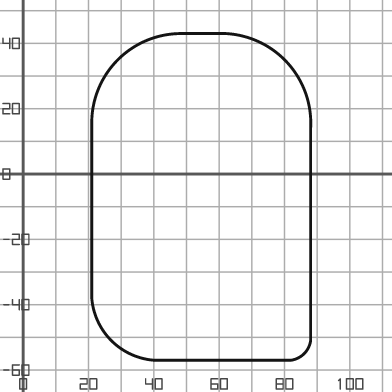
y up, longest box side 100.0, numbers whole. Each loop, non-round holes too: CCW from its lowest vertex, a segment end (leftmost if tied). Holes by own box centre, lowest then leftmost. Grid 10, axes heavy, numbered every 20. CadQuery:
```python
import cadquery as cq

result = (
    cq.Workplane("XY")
    .moveTo(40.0, -57.0)
    .lineTo(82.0, -57.0)
    .threePointArc((86.0, -55.0), (88.0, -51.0))
    .lineTo(88.0, 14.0)
    .threePointArc((80.0, 35.0), (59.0, 43.0))
    .lineTo(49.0, 43.0)
    .threePointArc((29.0, 35.0), (21.0, 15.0))
    .lineTo(21.0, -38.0)
    .threePointArc((27.0, -51.0), (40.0, -57.0))
    .close()
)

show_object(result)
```